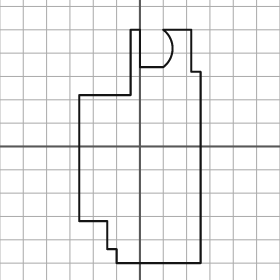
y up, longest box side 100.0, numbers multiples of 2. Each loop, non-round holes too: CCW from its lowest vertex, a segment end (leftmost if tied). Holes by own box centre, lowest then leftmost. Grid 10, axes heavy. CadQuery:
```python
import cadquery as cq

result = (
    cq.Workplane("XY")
    .moveTo(-10.0, -50.0)
    .lineTo(26.0, -50.0)
    .lineTo(26.0, 32.0)
    .lineTo(22.0, 32.0)
    .lineTo(22.0, 50.0)
    .lineTo(10.0, 50.0)
    .threePointArc((14.0, 42.0), (10.0, 34.0))
    .lineTo(0.0, 34.0)
    .lineTo(0.0, 50.0)
    .lineTo(-4.0, 50.0)
    .lineTo(-4.0, 22.0)
    .lineTo(-26.0, 22.0)
    .lineTo(-26.0, -32.0)
    .lineTo(-14.0, -32.0)
    .lineTo(-14.0, -44.0)
    .lineTo(-10.0, -44.0)
    .close()
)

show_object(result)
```